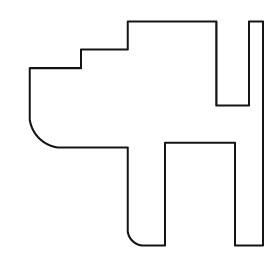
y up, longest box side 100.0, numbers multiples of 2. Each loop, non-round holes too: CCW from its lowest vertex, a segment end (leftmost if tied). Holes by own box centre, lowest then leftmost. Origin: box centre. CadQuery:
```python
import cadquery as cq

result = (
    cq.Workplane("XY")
    .moveTo(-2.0, -48.0)
    .lineTo(8.0, -48.0)
    .lineTo(8.0, -4.0)
    .lineTo(38.0, -4.0)
    .lineTo(38.0, -48.0)
    .lineTo(50.0, -48.0)
    .lineTo(50.0, 48.0)
    .lineTo(44.0, 48.0)
    .lineTo(44.0, 12.0)
    .lineTo(30.0, 12.0)
    .lineTo(30.0, 48.0)
    .lineTo(-8.0, 48.0)
    .lineTo(-8.0, 36.0)
    .lineTo(-28.0, 36.0)
    .lineTo(-28.0, 28.0)
    .lineTo(-50.0, 28.0)
    .lineTo(-50.0, 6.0)
    .threePointArc((-46.0, -2.0), (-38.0, -6.0))
    .lineTo(-8.0, -6.0)
    .lineTo(-8.0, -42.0)
    .threePointArc((-6.0, -46.0), (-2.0, -48.0))
    .close()
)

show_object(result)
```